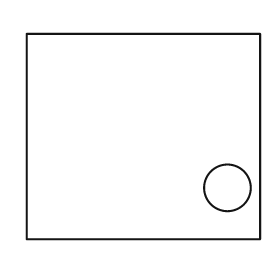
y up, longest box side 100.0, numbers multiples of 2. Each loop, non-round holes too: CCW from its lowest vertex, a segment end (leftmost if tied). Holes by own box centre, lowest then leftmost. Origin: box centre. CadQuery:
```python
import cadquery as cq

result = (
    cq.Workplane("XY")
    .moveTo(-50.0, -44.0)
    .lineTo(50.0, -44.0)
    .lineTo(50.0, 44.0)
    .lineTo(-50.0, 44.0)
    .close()
    .moveTo(36.0, -22.0)
    .circle(10.0)
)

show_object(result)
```